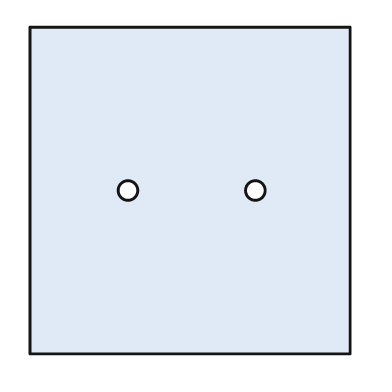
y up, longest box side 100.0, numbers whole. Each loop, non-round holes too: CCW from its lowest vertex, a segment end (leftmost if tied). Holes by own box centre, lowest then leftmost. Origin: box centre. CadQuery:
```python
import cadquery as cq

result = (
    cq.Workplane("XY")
    .moveTo(-49.0, -50.0)
    .lineTo(49.0, -50.0)
    .lineTo(49.0, 50.0)
    .lineTo(-49.0, 50.0)
    .close()
    .moveTo(-19.0, 0.0)
    .circle(3.0)
    .moveTo(20.0, 0.0)
    .circle(3.0)
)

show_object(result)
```